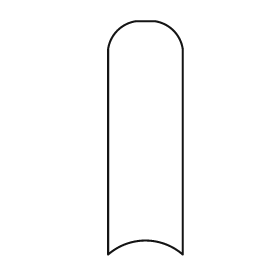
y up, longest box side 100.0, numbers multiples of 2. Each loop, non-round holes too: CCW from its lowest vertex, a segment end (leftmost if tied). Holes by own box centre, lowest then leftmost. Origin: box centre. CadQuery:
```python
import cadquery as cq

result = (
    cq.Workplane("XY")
    .moveTo(-16.0, -50.0)
    .threePointArc((0.0, -44.0), (16.0, -50.0))
    .lineTo(16.0, 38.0)
    .threePointArc((12.0, 46.0), (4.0, 50.0))
    .lineTo(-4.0, 50.0)
    .threePointArc((-12.0, 46.0), (-16.0, 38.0))
    .close()
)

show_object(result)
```